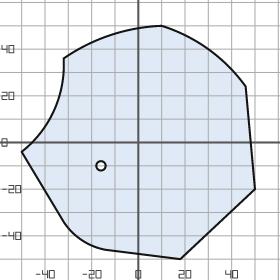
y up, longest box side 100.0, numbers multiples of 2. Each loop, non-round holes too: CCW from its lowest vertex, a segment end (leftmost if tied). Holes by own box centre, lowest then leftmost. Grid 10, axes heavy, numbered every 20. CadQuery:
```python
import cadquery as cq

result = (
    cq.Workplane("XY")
    .moveTo(18.0, -50.0)
    .lineTo(50.0, -20.0)
    .lineTo(46.0, 24.0)
    .threePointArc((30.0, 40.0), (10.0, 50.0))
    .threePointArc((-12.0, 46.0), (-32.0, 36.0))
    .threePointArc((-36.0, 14.0), (-50.0, -4.0))
    .lineTo(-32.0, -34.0)
    .threePointArc((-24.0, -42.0), (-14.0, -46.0))
    .close()
    .moveTo(-16.0, -10.0)
    .circle(2.0)
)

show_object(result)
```